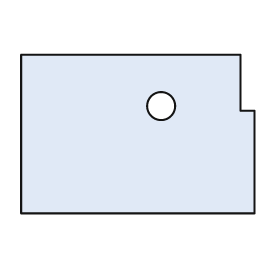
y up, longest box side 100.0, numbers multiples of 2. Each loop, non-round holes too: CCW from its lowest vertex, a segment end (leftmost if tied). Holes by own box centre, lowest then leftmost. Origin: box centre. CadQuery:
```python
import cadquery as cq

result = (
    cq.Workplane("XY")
    .moveTo(-50.0, -34.0)
    .lineTo(50.0, -34.0)
    .lineTo(50.0, 10.0)
    .lineTo(44.0, 10.0)
    .lineTo(44.0, 34.0)
    .lineTo(-50.0, 34.0)
    .close()
    .moveTo(10.0, 12.0)
    .circle(6.0)
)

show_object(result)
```